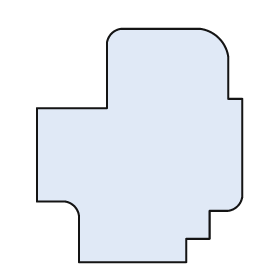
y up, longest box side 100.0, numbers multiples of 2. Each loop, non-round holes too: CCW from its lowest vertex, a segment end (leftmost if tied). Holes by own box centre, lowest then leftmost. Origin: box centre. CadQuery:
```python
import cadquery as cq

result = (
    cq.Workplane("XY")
    .moveTo(-26.0, -50.0)
    .lineTo(20.0, -50.0)
    .lineTo(20.0, -40.0)
    .lineTo(30.0, -40.0)
    .lineTo(30.0, -28.0)
    .lineTo(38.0, -28.0)
    .threePointArc((42.0, -26.0), (44.0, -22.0))
    .lineTo(44.0, 20.0)
    .lineTo(38.0, 20.0)
    .lineTo(38.0, 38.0)
    .threePointArc((34.0, 46.0), (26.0, 50.0))
    .lineTo(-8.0, 50.0)
    .threePointArc((-12.0, 48.0), (-14.0, 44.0))
    .lineTo(-14.0, 16.0)
    .lineTo(-44.0, 16.0)
    .lineTo(-44.0, -24.0)
    .lineTo(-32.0, -24.0)
    .threePointArc((-28.0, -26.0), (-26.0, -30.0))
    .close()
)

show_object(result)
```